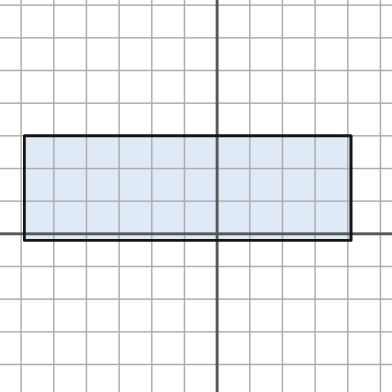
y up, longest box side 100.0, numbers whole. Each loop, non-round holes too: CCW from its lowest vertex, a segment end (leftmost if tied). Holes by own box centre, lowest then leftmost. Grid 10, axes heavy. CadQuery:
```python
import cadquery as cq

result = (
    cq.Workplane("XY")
    .moveTo(-59.0, -2.0)
    .lineTo(41.0, -2.0)
    .lineTo(41.0, 30.0)
    .lineTo(-59.0, 30.0)
    .close()
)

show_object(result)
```